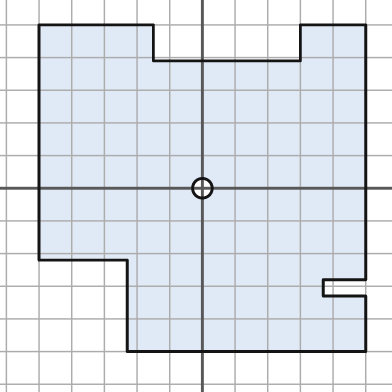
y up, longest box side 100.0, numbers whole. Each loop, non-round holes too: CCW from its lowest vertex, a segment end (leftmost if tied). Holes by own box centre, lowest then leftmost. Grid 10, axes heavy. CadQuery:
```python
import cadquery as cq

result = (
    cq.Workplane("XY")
    .moveTo(-23.0, -50.0)
    .lineTo(50.0, -50.0)
    .lineTo(50.0, -33.0)
    .lineTo(37.0, -33.0)
    .lineTo(37.0, -28.0)
    .lineTo(50.0, -28.0)
    .lineTo(50.0, 50.0)
    .lineTo(30.0, 50.0)
    .lineTo(30.0, 39.0)
    .lineTo(-15.0, 39.0)
    .lineTo(-15.0, 50.0)
    .lineTo(-50.0, 50.0)
    .lineTo(-50.0, -22.0)
    .lineTo(-23.0, -22.0)
    .close()
    .moveTo(0.0, 0.0)
    .circle(3.0)
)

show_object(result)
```